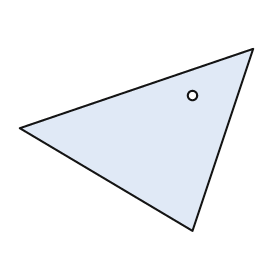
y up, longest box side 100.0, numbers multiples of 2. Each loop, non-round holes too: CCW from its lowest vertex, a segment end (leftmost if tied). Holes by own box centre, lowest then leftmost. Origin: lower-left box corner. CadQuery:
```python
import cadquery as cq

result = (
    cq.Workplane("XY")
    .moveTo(74.0, 0.0)
    .lineTo(100.0, 78.0)
    .lineTo(0.0, 44.0)
    .close()
    .moveTo(74.0, 58.0)
    .circle(2.0)
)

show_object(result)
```